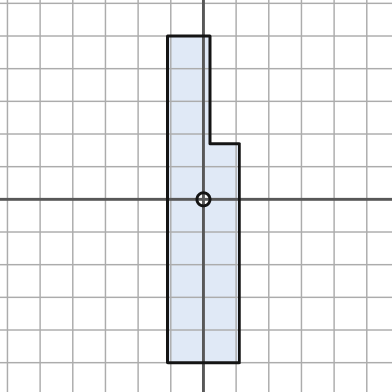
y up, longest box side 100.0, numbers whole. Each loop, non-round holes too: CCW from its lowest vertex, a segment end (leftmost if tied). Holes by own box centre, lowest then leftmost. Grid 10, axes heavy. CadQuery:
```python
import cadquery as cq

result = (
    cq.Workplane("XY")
    .moveTo(-11.0, -50.0)
    .lineTo(11.0, -50.0)
    .lineTo(11.0, 17.0)
    .lineTo(2.0, 17.0)
    .lineTo(2.0, 50.0)
    .lineTo(-11.0, 50.0)
    .close()
    .moveTo(0.0, 0.0)
    .circle(2.0)
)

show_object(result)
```